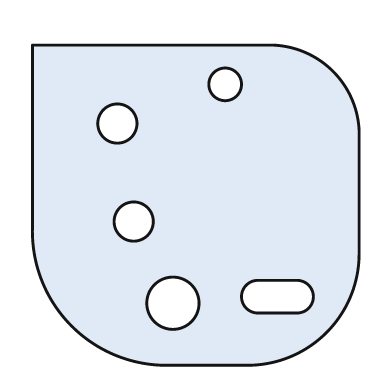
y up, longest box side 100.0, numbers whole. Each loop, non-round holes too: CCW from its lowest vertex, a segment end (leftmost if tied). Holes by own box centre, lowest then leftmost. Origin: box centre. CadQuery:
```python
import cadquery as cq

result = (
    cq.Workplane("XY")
    .moveTo(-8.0, -49.0)
    .lineTo(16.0, -49.0)
    .threePointArc((40.0, -39.0), (50.0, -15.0))
    .lineTo(50.0, 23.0)
    .threePointArc((42.0, 41.0), (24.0, 49.0))
    .lineTo(-50.0, 49.0)
    .lineTo(-50.0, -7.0)
    .threePointArc((-38.0, -37.0), (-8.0, -49.0))
    .close()
    .moveTo(-7.0, -30.0)
    .circle(8.0)
    .moveTo(19.0, -33.0)
    .lineTo(31.0, -33.0)
    .threePointArc((36.0, -28.0), (31.0, -23.0))
    .lineTo(19.0, -23.0)
    .threePointArc((14.0, -28.0), (19.0, -33.0))
    .close()
    .moveTo(-19.0, -5.0)
    .circle(6.0)
    .moveTo(-24.0, 25.0)
    .circle(6.0)
    .moveTo(9.0, 37.0)
    .circle(5.0)
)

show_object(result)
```